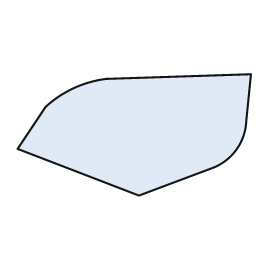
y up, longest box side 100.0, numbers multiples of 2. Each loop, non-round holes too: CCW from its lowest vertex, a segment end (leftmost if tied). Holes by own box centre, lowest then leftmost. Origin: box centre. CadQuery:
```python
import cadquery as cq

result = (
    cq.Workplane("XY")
    .moveTo(2.0, -26.0)
    .lineTo(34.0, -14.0)
    .threePointArc((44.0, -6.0), (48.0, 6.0))
    .lineTo(50.0, 26.0)
    .lineTo(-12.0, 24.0)
    .threePointArc((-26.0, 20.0), (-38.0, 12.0))
    .lineTo(-50.0, -6.0)
    .close()
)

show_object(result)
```